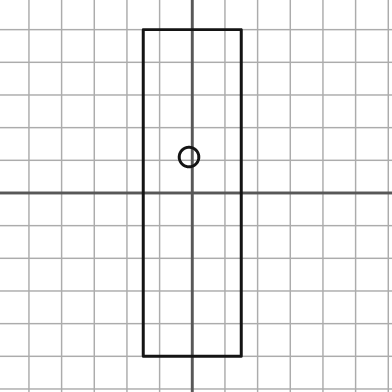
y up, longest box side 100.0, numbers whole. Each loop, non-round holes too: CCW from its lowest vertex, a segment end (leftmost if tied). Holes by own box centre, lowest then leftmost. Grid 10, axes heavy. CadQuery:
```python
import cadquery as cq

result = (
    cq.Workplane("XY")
    .moveTo(-15.0, -50.0)
    .lineTo(15.0, -50.0)
    .lineTo(15.0, 50.0)
    .lineTo(-15.0, 50.0)
    .close()
    .moveTo(-1.0, 11.0)
    .circle(3.0)
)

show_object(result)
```